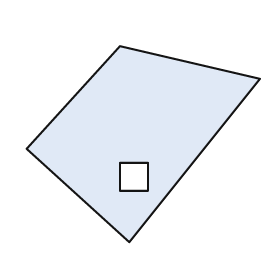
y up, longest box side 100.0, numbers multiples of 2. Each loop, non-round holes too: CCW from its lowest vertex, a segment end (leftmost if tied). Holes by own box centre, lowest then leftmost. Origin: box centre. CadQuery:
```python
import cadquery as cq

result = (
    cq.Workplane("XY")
    .moveTo(-6.0, -42.0)
    .lineTo(50.0, 28.0)
    .lineTo(-10.0, 42.0)
    .lineTo(-50.0, -2.0)
    .close()
    .moveTo(-10.0, -20.0)
    .lineTo(2.0, -20.0)
    .lineTo(2.0, -8.0)
    .lineTo(-10.0, -8.0)
    .close()
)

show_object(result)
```